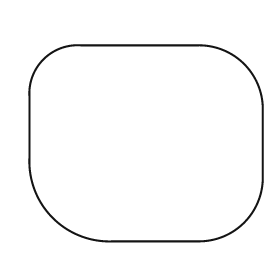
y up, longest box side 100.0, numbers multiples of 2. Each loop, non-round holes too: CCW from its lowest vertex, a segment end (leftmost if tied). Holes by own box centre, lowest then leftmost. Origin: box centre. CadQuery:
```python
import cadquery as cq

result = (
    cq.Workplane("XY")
    .moveTo(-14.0, -42.0)
    .lineTo(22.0, -42.0)
    .threePointArc((42.0, -34.0), (50.0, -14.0))
    .lineTo(50.0, 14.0)
    .threePointArc((42.0, 34.0), (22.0, 42.0))
    .lineTo(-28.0, 42.0)
    .threePointArc((-44.0, 36.0), (-50.0, 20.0))
    .lineTo(-50.0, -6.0)
    .threePointArc((-40.0, -32.0), (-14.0, -42.0))
    .close()
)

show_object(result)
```